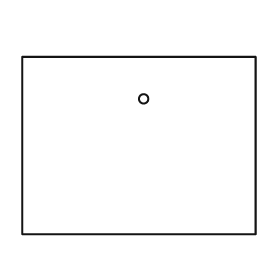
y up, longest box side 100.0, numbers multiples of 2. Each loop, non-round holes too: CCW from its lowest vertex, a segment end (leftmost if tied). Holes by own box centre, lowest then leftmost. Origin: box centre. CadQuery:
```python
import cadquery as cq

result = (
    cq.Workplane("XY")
    .moveTo(-50.0, -38.0)
    .lineTo(50.0, -38.0)
    .lineTo(50.0, 38.0)
    .lineTo(-50.0, 38.0)
    .close()
    .moveTo(2.0, 20.0)
    .circle(2.0)
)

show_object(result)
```